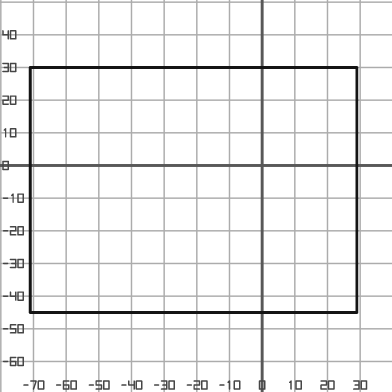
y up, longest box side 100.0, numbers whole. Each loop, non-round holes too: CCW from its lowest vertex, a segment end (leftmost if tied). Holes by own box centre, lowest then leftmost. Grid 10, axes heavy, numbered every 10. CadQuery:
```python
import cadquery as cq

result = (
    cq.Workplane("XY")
    .moveTo(-71.0, -45.0)
    .lineTo(29.0, -45.0)
    .lineTo(29.0, 30.0)
    .lineTo(-71.0, 30.0)
    .close()
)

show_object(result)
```